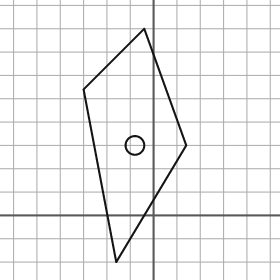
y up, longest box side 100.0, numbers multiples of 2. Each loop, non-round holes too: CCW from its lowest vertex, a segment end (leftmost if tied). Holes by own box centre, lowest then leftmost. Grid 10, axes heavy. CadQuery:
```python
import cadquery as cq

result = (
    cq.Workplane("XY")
    .moveTo(-16.0, -20.0)
    .lineTo(14.0, 30.0)
    .lineTo(-4.0, 80.0)
    .lineTo(-30.0, 54.0)
    .close()
    .moveTo(-8.0, 30.0)
    .circle(4.0)
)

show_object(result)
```